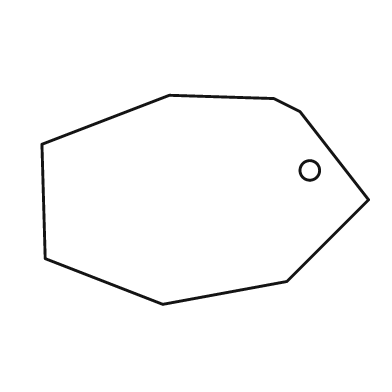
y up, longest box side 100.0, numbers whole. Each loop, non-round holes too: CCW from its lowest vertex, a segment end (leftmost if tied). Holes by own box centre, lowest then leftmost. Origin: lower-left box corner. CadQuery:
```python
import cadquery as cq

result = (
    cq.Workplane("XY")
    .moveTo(37.0, 0.0)
    .lineTo(75.0, 7.0)
    .lineTo(100.0, 32.0)
    .lineTo(79.0, 59.0)
    .lineTo(71.0, 63.0)
    .lineTo(39.0, 64.0)
    .lineTo(0.0, 49.0)
    .lineTo(1.0, 14.0)
    .close()
    .moveTo(82.0, 41.0)
    .circle(3.0)
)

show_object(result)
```